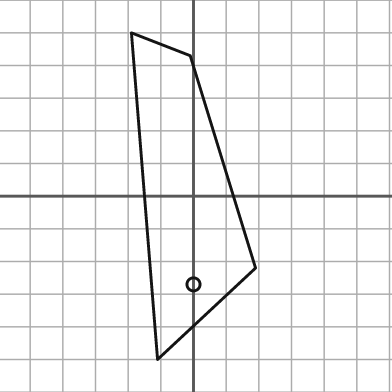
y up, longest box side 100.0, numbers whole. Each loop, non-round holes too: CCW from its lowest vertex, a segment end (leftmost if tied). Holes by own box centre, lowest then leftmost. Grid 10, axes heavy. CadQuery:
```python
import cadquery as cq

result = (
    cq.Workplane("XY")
    .moveTo(-11.0, -50.0)
    .lineTo(19.0, -22.0)
    .lineTo(-1.0, 43.0)
    .lineTo(-19.0, 50.0)
    .close()
    .moveTo(0.0, -27.0)
    .circle(2.0)
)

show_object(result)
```